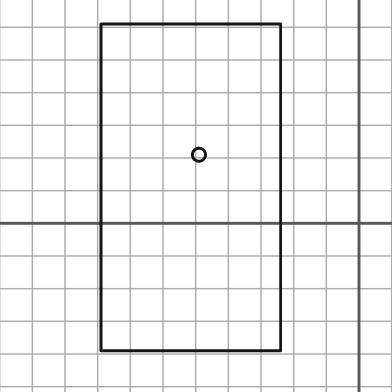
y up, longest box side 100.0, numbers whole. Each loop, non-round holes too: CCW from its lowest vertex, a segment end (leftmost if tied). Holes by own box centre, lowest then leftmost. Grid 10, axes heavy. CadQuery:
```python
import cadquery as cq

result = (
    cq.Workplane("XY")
    .moveTo(-79.0, -39.0)
    .lineTo(-24.0, -39.0)
    .lineTo(-24.0, 61.0)
    .lineTo(-79.0, 61.0)
    .close()
    .moveTo(-49.0, 21.0)
    .circle(2.0)
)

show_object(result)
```